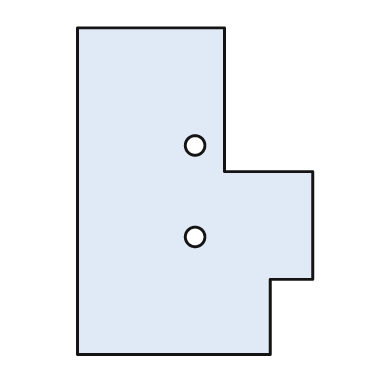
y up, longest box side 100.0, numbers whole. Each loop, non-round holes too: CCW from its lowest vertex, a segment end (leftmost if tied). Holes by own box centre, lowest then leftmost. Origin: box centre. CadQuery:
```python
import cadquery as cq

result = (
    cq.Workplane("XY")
    .moveTo(-36.0, -50.0)
    .lineTo(23.0, -50.0)
    .lineTo(23.0, -27.0)
    .lineTo(36.0, -27.0)
    .lineTo(36.0, 6.0)
    .lineTo(9.0, 6.0)
    .lineTo(9.0, 50.0)
    .lineTo(-36.0, 50.0)
    .close()
    .moveTo(0.0, -14.0)
    .circle(3.0)
    .moveTo(0.0, 14.0)
    .circle(3.0)
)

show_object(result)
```